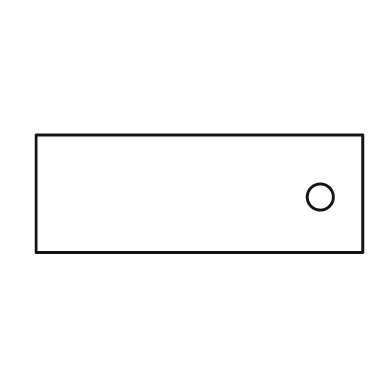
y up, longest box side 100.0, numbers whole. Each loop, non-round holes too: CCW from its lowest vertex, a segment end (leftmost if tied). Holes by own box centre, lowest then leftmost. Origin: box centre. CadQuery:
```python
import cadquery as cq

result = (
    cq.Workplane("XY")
    .moveTo(-50.0, -18.0)
    .lineTo(50.0, -18.0)
    .lineTo(50.0, 18.0)
    .lineTo(-50.0, 18.0)
    .close()
    .moveTo(37.0, -1.0)
    .circle(4.0)
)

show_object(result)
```